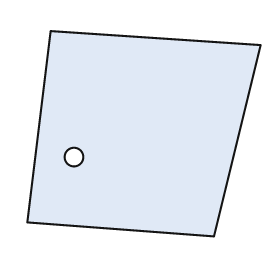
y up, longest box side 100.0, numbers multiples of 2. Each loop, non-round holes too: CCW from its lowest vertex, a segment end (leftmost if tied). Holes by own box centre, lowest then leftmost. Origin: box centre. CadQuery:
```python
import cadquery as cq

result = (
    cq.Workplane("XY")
    .moveTo(30.0, -44.0)
    .lineTo(50.0, 38.0)
    .lineTo(-40.0, 44.0)
    .lineTo(-50.0, -38.0)
    .close()
    .moveTo(-30.0, -10.0)
    .circle(4.0)
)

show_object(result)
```